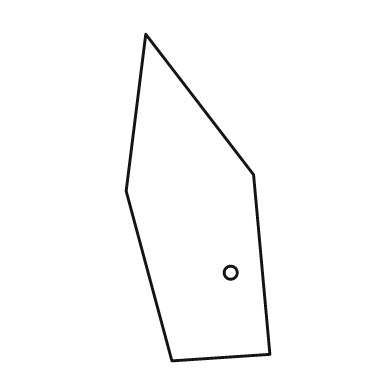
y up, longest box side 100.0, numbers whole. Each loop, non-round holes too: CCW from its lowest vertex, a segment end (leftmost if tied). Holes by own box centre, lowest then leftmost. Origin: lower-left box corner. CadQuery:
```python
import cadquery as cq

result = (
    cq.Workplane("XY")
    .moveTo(14.0, 0.0)
    .lineTo(44.0, 2.0)
    .lineTo(39.0, 57.0)
    .lineTo(6.0, 100.0)
    .lineTo(0.0, 52.0)
    .close()
    .moveTo(32.0, 27.0)
    .circle(2.0)
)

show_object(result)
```